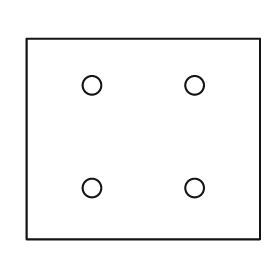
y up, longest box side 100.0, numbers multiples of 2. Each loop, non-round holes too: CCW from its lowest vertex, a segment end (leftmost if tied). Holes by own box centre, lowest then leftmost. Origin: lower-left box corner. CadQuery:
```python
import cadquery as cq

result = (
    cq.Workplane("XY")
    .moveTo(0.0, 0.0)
    .lineTo(100.0, 0.0)
    .lineTo(100.0, 86.0)
    .lineTo(0.0, 86.0)
    .close()
    .moveTo(28.0, 22.0)
    .circle(4.0)
    .moveTo(72.0, 22.0)
    .circle(4.0)
    .moveTo(28.0, 66.0)
    .circle(4.0)
    .moveTo(72.0, 66.0)
    .circle(4.0)
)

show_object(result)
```